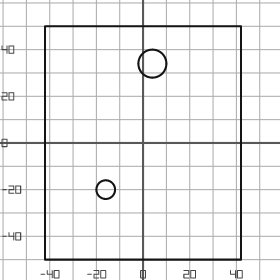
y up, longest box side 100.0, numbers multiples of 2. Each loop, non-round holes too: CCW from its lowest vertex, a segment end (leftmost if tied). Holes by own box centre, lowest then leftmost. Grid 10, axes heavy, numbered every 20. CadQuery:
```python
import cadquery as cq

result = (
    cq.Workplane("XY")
    .moveTo(-42.0, -50.0)
    .lineTo(42.0, -50.0)
    .lineTo(42.0, 50.0)
    .lineTo(-42.0, 50.0)
    .close()
    .moveTo(-16.0, -20.0)
    .circle(4.0)
    .moveTo(4.0, 34.0)
    .circle(6.0)
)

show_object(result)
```